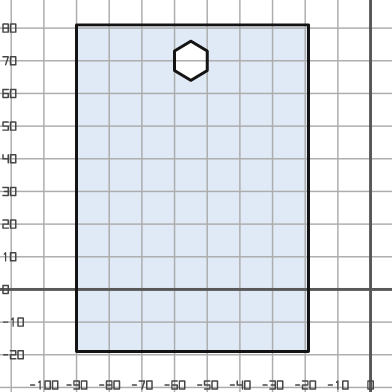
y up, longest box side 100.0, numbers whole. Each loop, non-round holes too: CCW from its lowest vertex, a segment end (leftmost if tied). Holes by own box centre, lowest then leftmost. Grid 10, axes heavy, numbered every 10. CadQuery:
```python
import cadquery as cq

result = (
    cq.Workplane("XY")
    .moveTo(-90.0, -19.0)
    .lineTo(-19.0, -19.0)
    .lineTo(-19.0, 81.0)
    .lineTo(-90.0, 81.0)
    .close()
    .moveTo(-55.0, 64.0)
    .lineTo(-50.0, 67.0)
    .lineTo(-50.0, 73.0)
    .lineTo(-55.0, 76.0)
    .lineTo(-60.0, 73.0)
    .lineTo(-60.0, 67.0)
    .close()
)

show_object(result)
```